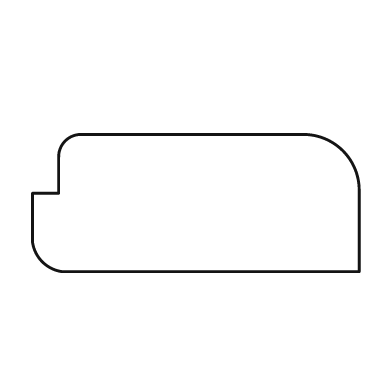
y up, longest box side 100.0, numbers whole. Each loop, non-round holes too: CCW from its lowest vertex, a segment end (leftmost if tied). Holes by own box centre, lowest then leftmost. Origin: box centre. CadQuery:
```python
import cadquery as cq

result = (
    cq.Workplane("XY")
    .moveTo(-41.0, -21.0)
    .lineTo(50.0, -21.0)
    .lineTo(50.0, 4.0)
    .threePointArc((45.0, 16.0), (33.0, 21.0))
    .lineTo(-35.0, 21.0)
    .threePointArc((-40.0, 19.0), (-42.0, 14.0))
    .lineTo(-42.0, 3.0)
    .lineTo(-50.0, 3.0)
    .lineTo(-50.0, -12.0)
    .threePointArc((-47.0, -18.0), (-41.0, -21.0))
    .close()
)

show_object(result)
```